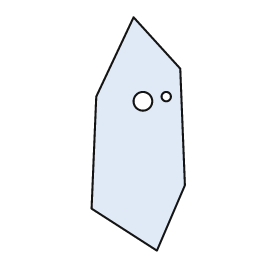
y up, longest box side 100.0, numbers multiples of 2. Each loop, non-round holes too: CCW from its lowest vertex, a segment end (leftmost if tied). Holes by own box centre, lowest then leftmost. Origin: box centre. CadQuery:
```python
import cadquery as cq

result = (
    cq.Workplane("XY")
    .moveTo(8.0, -50.0)
    .lineTo(20.0, -22.0)
    .lineTo(18.0, 28.0)
    .lineTo(-2.0, 50.0)
    .lineTo(-18.0, 16.0)
    .lineTo(-20.0, -32.0)
    .close()
    .moveTo(2.0, 14.0)
    .circle(4.0)
    .moveTo(12.0, 16.0)
    .circle(2.0)
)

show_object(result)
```